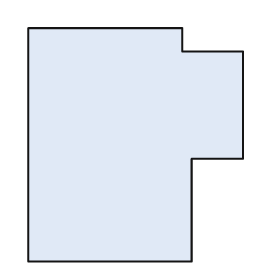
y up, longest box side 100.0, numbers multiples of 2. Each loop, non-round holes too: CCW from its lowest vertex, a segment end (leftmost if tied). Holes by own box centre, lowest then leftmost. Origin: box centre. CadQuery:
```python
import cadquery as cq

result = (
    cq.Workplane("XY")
    .moveTo(-46.0, -50.0)
    .lineTo(24.0, -50.0)
    .lineTo(24.0, -6.0)
    .lineTo(46.0, -6.0)
    .lineTo(46.0, 40.0)
    .lineTo(20.0, 40.0)
    .lineTo(20.0, 50.0)
    .lineTo(-46.0, 50.0)
    .close()
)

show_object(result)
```